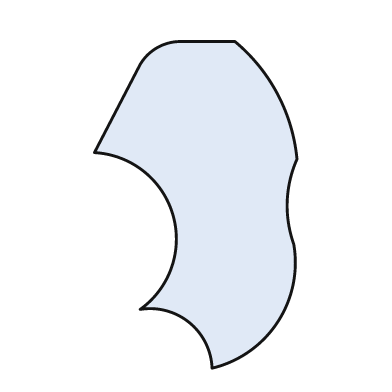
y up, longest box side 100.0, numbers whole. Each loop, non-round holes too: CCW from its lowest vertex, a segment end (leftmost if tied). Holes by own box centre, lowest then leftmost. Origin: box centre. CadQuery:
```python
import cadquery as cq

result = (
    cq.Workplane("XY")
    .moveTo(5.0, -50.0)
    .threePointArc((25.0, -36.0), (30.0, -12.0))
    .threePointArc((28.0, 1.0), (31.0, 14.0))
    .threePointArc((25.0, 34.0), (12.0, 50.0))
    .lineTo(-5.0, 50.0)
    .threePointArc((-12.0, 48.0), (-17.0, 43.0))
    .lineTo(-31.0, 16.0)
    .threePointArc((-7.0, -3.0), (-17.0, -32.0))
    .threePointArc((-2.0, -36.0), (5.0, -50.0))
    .close()
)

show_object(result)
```